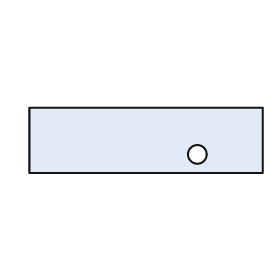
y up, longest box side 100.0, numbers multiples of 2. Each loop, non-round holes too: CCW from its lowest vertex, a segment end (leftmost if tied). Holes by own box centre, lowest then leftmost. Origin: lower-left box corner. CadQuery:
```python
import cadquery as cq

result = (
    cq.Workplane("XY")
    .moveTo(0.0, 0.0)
    .lineTo(100.0, 0.0)
    .lineTo(100.0, 28.0)
    .lineTo(0.0, 28.0)
    .close()
    .moveTo(72.0, 8.0)
    .circle(4.0)
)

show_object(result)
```